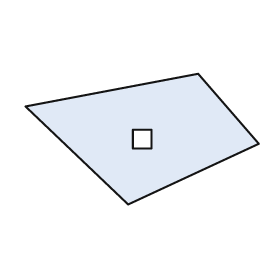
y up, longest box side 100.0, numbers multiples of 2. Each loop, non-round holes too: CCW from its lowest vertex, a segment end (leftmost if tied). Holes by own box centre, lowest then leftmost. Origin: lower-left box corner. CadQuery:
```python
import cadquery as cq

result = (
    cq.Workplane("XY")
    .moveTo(44.0, 0.0)
    .lineTo(100.0, 26.0)
    .lineTo(74.0, 56.0)
    .lineTo(0.0, 42.0)
    .close()
    .moveTo(46.0, 24.0)
    .lineTo(54.0, 24.0)
    .lineTo(54.0, 32.0)
    .lineTo(46.0, 32.0)
    .close()
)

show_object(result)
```